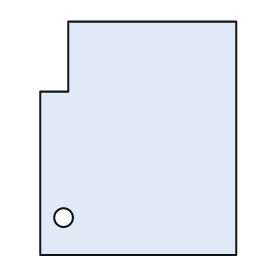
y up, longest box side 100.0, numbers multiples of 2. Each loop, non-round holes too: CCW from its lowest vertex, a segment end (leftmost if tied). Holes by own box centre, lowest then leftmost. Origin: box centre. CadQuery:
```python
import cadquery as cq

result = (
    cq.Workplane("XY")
    .moveTo(-42.0, -50.0)
    .lineTo(42.0, -50.0)
    .lineTo(42.0, 50.0)
    .lineTo(-30.0, 50.0)
    .lineTo(-30.0, 20.0)
    .lineTo(-42.0, 20.0)
    .close()
    .moveTo(-32.0, -34.0)
    .circle(4.0)
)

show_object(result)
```